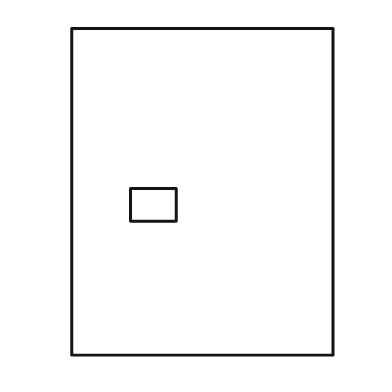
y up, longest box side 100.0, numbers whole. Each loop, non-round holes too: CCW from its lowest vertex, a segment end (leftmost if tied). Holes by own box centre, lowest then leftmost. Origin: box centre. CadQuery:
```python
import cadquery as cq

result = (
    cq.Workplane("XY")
    .moveTo(-40.0, -50.0)
    .lineTo(40.0, -50.0)
    .lineTo(40.0, 50.0)
    .lineTo(-40.0, 50.0)
    .close()
    .moveTo(-22.0, -9.0)
    .lineTo(-8.0, -9.0)
    .lineTo(-8.0, 1.0)
    .lineTo(-22.0, 1.0)
    .close()
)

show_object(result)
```